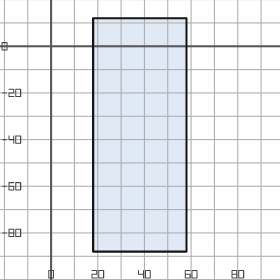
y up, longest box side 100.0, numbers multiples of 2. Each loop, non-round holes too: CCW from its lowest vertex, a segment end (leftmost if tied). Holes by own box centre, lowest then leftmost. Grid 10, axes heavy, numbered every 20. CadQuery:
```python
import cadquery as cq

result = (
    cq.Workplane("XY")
    .moveTo(18.0, -88.0)
    .lineTo(58.0, -88.0)
    .lineTo(58.0, 12.0)
    .lineTo(18.0, 12.0)
    .close()
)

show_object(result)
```